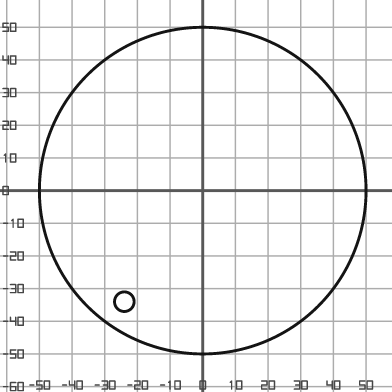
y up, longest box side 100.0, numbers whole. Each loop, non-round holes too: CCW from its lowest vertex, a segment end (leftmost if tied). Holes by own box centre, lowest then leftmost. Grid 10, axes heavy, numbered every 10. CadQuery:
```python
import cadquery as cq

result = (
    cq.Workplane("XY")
    .moveTo(0.0, 0.0)
    .circle(50.0)
    .moveTo(-24.0, -34.0)
    .circle(3.0)
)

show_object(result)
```